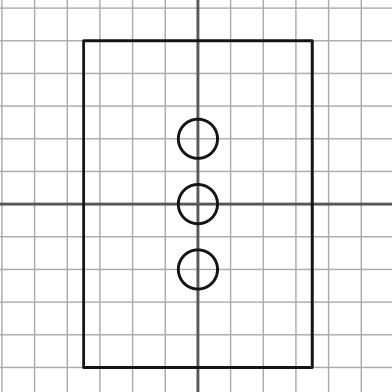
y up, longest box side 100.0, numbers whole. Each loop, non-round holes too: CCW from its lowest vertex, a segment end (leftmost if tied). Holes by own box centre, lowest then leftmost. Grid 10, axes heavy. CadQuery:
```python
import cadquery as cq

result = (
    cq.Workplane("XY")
    .moveTo(-35.0, -50.0)
    .lineTo(35.0, -50.0)
    .lineTo(35.0, 50.0)
    .lineTo(-35.0, 50.0)
    .close()
    .moveTo(0.0, -20.0)
    .circle(6.0)
    .moveTo(0.0, 0.0)
    .circle(6.0)
    .moveTo(0.0, 20.0)
    .circle(6.0)
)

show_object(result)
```